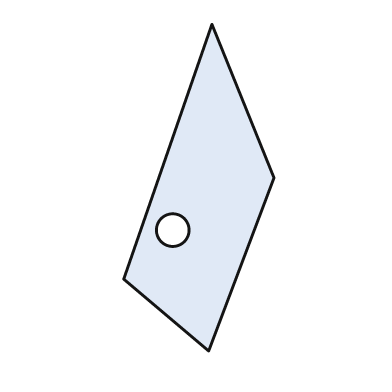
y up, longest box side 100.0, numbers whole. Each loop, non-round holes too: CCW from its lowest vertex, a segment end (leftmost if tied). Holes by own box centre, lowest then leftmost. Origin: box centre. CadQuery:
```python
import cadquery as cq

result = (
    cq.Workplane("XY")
    .moveTo(3.0, -50.0)
    .lineTo(23.0, 3.0)
    .lineTo(4.0, 50.0)
    .lineTo(-23.0, -28.0)
    .close()
    .moveTo(-8.0, -13.0)
    .circle(5.0)
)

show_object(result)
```